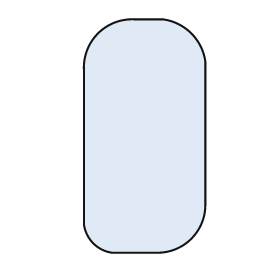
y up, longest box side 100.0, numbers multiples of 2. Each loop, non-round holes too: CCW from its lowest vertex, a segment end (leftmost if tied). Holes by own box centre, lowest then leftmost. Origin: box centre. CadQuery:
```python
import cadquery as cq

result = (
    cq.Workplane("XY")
    .moveTo(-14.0, -50.0)
    .lineTo(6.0, -50.0)
    .threePointArc((20.0, -44.0), (26.0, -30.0))
    .lineTo(26.0, 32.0)
    .threePointArc((20.0, 44.0), (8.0, 50.0))
    .lineTo(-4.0, 50.0)
    .threePointArc((-20.0, 44.0), (-26.0, 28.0))
    .lineTo(-26.0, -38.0)
    .threePointArc((-22.0, -46.0), (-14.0, -50.0))
    .close()
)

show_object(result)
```